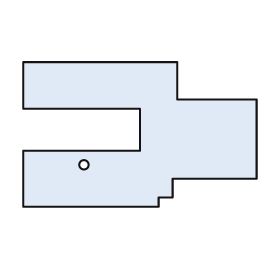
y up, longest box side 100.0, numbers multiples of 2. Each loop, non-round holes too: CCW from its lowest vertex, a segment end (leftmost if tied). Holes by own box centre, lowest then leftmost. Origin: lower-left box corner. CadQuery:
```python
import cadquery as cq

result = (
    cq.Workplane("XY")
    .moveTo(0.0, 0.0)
    .lineTo(58.0, 0.0)
    .lineTo(58.0, 4.0)
    .lineTo(64.0, 4.0)
    .lineTo(64.0, 12.0)
    .lineTo(100.0, 12.0)
    .lineTo(100.0, 46.0)
    .lineTo(66.0, 46.0)
    .lineTo(66.0, 62.0)
    .lineTo(0.0, 62.0)
    .lineTo(0.0, 42.0)
    .lineTo(50.0, 42.0)
    .lineTo(50.0, 24.0)
    .lineTo(0.0, 24.0)
    .close()
    .moveTo(26.0, 18.0)
    .circle(2.0)
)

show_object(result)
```